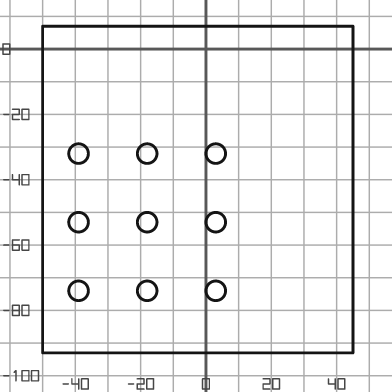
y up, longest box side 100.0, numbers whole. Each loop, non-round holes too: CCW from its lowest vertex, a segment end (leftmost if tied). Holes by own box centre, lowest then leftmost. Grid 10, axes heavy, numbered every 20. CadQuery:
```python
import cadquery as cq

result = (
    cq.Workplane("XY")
    .moveTo(-50.0, -93.0)
    .lineTo(45.0, -93.0)
    .lineTo(45.0, 7.0)
    .lineTo(-50.0, 7.0)
    .close()
    .moveTo(-39.0, -74.0)
    .circle(3.0)
    .moveTo(-18.0, -74.0)
    .circle(3.0)
    .moveTo(3.0, -74.0)
    .circle(3.0)
    .moveTo(-39.0, -53.0)
    .circle(3.0)
    .moveTo(-18.0, -53.0)
    .circle(3.0)
    .moveTo(3.0, -53.0)
    .circle(3.0)
    .moveTo(-39.0, -32.0)
    .circle(3.0)
    .moveTo(-18.0, -32.0)
    .circle(3.0)
    .moveTo(3.0, -32.0)
    .circle(3.0)
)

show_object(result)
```